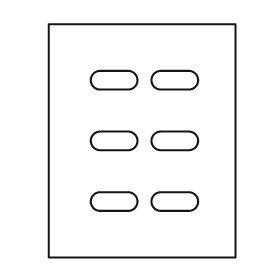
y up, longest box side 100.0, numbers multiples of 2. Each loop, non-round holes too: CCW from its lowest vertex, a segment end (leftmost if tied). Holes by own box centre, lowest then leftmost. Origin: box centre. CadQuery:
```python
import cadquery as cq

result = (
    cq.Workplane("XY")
    .moveTo(-40.0, -50.0)
    .lineTo(40.0, -50.0)
    .lineTo(40.0, 50.0)
    .lineTo(-40.0, 50.0)
    .close()
    .moveTo(-18.0, -30.0)
    .lineTo(-6.0, -30.0)
    .threePointArc((-2.0, -26.0), (-6.0, -22.0))
    .lineTo(-18.0, -22.0)
    .threePointArc((-22.0, -26.0), (-18.0, -30.0))
    .close()
    .moveTo(8.0, -30.0)
    .lineTo(20.0, -30.0)
    .threePointArc((24.0, -26.0), (20.0, -22.0))
    .lineTo(8.0, -22.0)
    .threePointArc((4.0, -26.0), (8.0, -30.0))
    .close()
    .moveTo(-18.0, -4.0)
    .lineTo(-6.0, -4.0)
    .threePointArc((-2.0, 0.0), (-6.0, 4.0))
    .lineTo(-18.0, 4.0)
    .threePointArc((-22.0, 0.0), (-18.0, -4.0))
    .close()
    .moveTo(8.0, -4.0)
    .lineTo(20.0, -4.0)
    .threePointArc((24.0, 0.0), (20.0, 4.0))
    .lineTo(8.0, 4.0)
    .threePointArc((4.0, 0.0), (8.0, -4.0))
    .close()
    .moveTo(-18.0, 22.0)
    .lineTo(-6.0, 22.0)
    .threePointArc((-2.0, 26.0), (-6.0, 30.0))
    .lineTo(-18.0, 30.0)
    .threePointArc((-22.0, 26.0), (-18.0, 22.0))
    .close()
    .moveTo(8.0, 22.0)
    .lineTo(20.0, 22.0)
    .threePointArc((24.0, 26.0), (20.0, 30.0))
    .lineTo(8.0, 30.0)
    .threePointArc((4.0, 26.0), (8.0, 22.0))
    .close()
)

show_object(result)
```